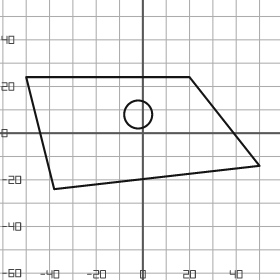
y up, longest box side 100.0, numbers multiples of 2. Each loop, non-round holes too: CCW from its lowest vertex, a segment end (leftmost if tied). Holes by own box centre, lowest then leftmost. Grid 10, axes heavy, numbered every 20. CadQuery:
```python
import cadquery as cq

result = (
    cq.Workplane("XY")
    .moveTo(-38.0, -24.0)
    .lineTo(50.0, -14.0)
    .lineTo(20.0, 24.0)
    .lineTo(-50.0, 24.0)
    .close()
    .moveTo(-2.0, 8.0)
    .circle(6.0)
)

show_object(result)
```